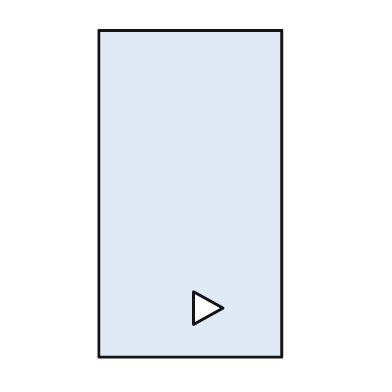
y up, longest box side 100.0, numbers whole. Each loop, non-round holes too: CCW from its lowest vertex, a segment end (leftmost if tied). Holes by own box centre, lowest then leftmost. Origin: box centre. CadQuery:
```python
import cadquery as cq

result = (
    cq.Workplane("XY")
    .moveTo(-28.0, -50.0)
    .lineTo(28.0, -50.0)
    .lineTo(28.0, 50.0)
    .lineTo(-28.0, 50.0)
    .close()
    .moveTo(1.0, -40.0)
    .lineTo(10.0, -35.0)
    .lineTo(1.0, -30.0)
    .close()
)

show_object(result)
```